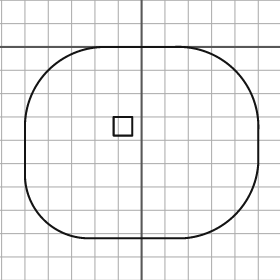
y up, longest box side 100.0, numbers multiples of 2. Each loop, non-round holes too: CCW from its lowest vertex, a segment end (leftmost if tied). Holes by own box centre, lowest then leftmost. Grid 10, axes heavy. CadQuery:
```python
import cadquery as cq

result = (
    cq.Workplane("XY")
    .moveTo(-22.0, -82.0)
    .lineTo(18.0, -82.0)
    .threePointArc((40.0, -72.0), (50.0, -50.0))
    .lineTo(50.0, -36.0)
    .threePointArc((40.0, -10.0), (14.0, 0.0))
    .lineTo(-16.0, 0.0)
    .threePointArc((-40.0, -10.0), (-50.0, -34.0))
    .lineTo(-50.0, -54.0)
    .threePointArc((-42.0, -74.0), (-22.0, -82.0))
    .close()
    .moveTo(-12.0, -38.0)
    .lineTo(-4.0, -38.0)
    .lineTo(-4.0, -30.0)
    .lineTo(-12.0, -30.0)
    .close()
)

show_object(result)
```